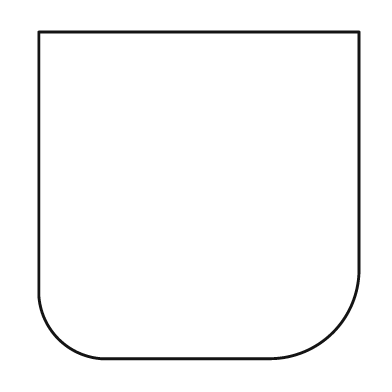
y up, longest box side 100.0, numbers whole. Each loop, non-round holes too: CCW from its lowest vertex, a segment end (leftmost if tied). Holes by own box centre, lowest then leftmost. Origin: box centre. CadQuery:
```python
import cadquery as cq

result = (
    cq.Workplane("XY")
    .moveTo(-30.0, -50.0)
    .lineTo(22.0, -50.0)
    .threePointArc((41.0, -42.0), (49.0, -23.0))
    .lineTo(49.0, 50.0)
    .lineTo(-49.0, 50.0)
    .lineTo(-49.0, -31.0)
    .threePointArc((-43.0, -44.0), (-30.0, -50.0))
    .close()
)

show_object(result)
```